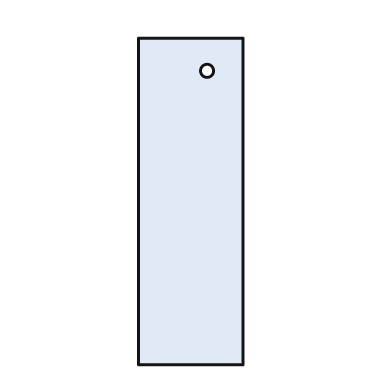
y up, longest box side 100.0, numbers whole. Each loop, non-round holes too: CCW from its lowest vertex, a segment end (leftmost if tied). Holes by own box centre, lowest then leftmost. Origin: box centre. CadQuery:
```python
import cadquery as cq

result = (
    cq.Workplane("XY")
    .moveTo(-16.0, -50.0)
    .lineTo(16.0, -50.0)
    .lineTo(16.0, 50.0)
    .lineTo(-16.0, 50.0)
    .close()
    .moveTo(5.0, 40.0)
    .circle(2.0)
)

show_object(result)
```